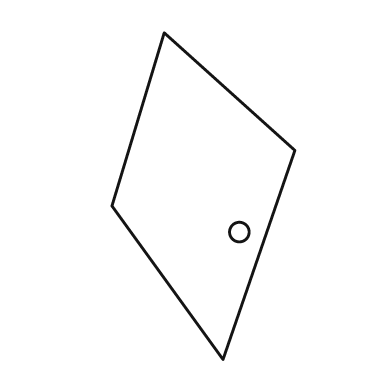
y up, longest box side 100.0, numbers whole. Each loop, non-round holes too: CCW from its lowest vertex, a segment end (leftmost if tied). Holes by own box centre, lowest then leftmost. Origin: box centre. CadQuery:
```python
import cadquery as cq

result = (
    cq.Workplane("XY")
    .moveTo(6.0, -50.0)
    .lineTo(28.0, 14.0)
    .lineTo(-12.0, 50.0)
    .lineTo(-28.0, -3.0)
    .close()
    .moveTo(11.0, -11.0)
    .circle(3.0)
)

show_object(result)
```